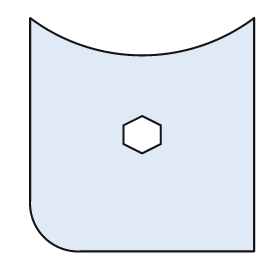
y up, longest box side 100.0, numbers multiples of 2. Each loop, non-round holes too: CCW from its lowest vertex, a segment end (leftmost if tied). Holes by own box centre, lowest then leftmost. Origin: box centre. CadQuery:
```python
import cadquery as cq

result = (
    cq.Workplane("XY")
    .moveTo(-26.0, -50.0)
    .lineTo(48.0, -50.0)
    .lineTo(48.0, 50.0)
    .threePointArc((0.0, 34.0), (-48.0, 50.0))
    .lineTo(-48.0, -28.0)
    .threePointArc((-42.0, -44.0), (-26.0, -50.0))
    .close()
    .moveTo(0.0, -8.0)
    .lineTo(8.0, -4.0)
    .lineTo(8.0, 4.0)
    .lineTo(0.0, 8.0)
    .lineTo(-8.0, 4.0)
    .lineTo(-8.0, -4.0)
    .close()
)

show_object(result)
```